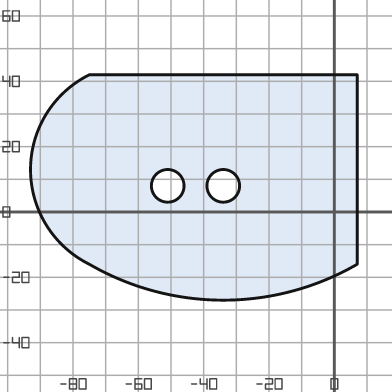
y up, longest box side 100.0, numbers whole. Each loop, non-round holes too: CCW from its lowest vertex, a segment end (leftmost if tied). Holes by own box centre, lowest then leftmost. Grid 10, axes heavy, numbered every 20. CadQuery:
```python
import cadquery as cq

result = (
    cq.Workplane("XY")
    .moveTo(-75.0, -16.0)
    .threePointArc((-34.0, -27.0), (7.0, -16.0))
    .lineTo(7.0, 42.0)
    .lineTo(-75.0, 42.0)
    .threePointArc((-93.0, 13.0), (-75.0, -16.0))
    .close()
    .moveTo(-51.0, 8.0)
    .circle(5.0)
    .moveTo(-34.0, 8.0)
    .circle(5.0)
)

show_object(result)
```